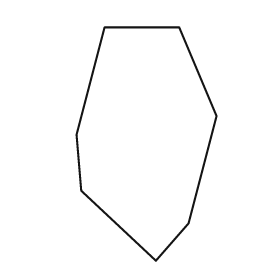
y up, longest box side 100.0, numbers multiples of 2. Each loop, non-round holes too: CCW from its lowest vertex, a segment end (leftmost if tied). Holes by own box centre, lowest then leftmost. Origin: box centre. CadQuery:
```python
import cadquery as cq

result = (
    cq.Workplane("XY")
    .moveTo(4.0, -50.0)
    .lineTo(18.0, -34.0)
    .lineTo(30.0, 12.0)
    .lineTo(14.0, 50.0)
    .lineTo(-18.0, 50.0)
    .lineTo(-30.0, 4.0)
    .lineTo(-28.0, -20.0)
    .close()
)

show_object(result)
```